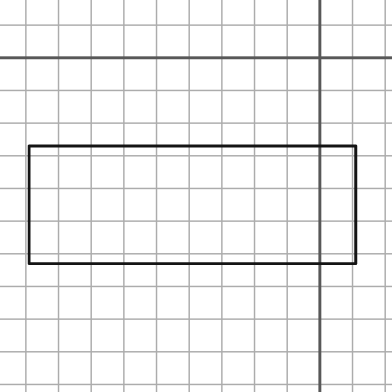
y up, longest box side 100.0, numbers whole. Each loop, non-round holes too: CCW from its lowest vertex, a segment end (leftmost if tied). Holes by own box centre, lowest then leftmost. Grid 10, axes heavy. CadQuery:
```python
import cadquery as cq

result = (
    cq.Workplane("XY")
    .moveTo(-89.0, -63.0)
    .lineTo(11.0, -63.0)
    .lineTo(11.0, -27.0)
    .lineTo(-89.0, -27.0)
    .close()
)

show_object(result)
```